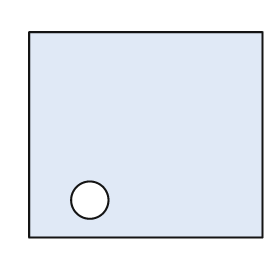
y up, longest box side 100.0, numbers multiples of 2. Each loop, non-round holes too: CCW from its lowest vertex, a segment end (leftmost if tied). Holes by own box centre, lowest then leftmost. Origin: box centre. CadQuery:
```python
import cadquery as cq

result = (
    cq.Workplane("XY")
    .moveTo(-50.0, -44.0)
    .lineTo(50.0, -44.0)
    .lineTo(50.0, 44.0)
    .lineTo(-50.0, 44.0)
    .close()
    .moveTo(-24.0, -28.0)
    .circle(8.0)
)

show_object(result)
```